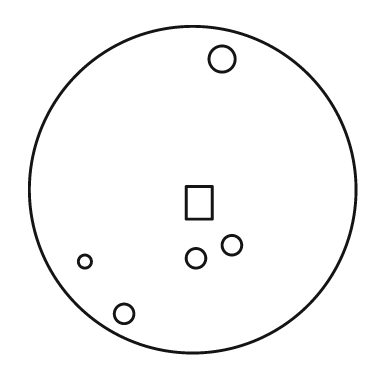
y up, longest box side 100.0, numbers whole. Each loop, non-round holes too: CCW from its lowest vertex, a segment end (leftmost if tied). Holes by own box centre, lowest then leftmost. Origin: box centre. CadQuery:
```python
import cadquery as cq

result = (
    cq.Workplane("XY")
    .moveTo(0.0, 0.0)
    .circle(50.0)
    .moveTo(-21.0, -38.0)
    .circle(3.0)
    .moveTo(-33.0, -22.0)
    .circle(2.0)
    .moveTo(1.0, -21.0)
    .circle(3.0)
    .moveTo(12.0, -17.0)
    .circle(3.0)
    .moveTo(-2.0, -9.0)
    .lineTo(6.0, -9.0)
    .lineTo(6.0, 1.0)
    .lineTo(-2.0, 1.0)
    .close()
    .moveTo(9.0, 40.0)
    .circle(4.0)
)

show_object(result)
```